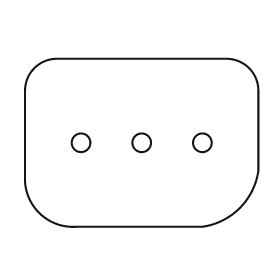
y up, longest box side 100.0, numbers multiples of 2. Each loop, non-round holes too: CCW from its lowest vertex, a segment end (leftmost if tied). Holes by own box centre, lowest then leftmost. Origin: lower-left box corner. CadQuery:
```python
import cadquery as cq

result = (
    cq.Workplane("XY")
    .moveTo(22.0, 0.0)
    .lineTo(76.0, 0.0)
    .threePointArc((92.0, 8.0), (100.0, 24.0))
    .lineTo(100.0, 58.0)
    .threePointArc((96.0, 68.0), (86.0, 72.0))
    .lineTo(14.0, 72.0)
    .threePointArc((4.0, 68.0), (0.0, 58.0))
    .lineTo(0.0, 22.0)
    .threePointArc((6.0, 6.0), (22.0, 0.0))
    .close()
    .moveTo(24.0, 36.0)
    .circle(4.0)
    .moveTo(50.0, 36.0)
    .circle(4.0)
    .moveTo(76.0, 36.0)
    .circle(4.0)
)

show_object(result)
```